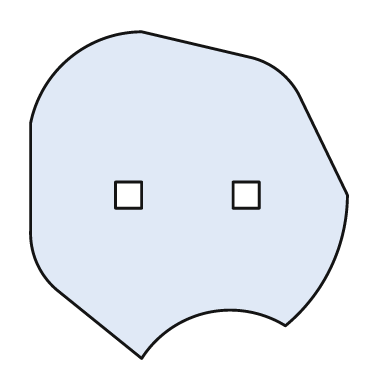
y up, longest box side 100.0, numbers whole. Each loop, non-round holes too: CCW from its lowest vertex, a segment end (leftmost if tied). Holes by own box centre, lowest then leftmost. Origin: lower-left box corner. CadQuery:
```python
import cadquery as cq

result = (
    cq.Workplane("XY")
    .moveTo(34.0, 0.0)
    .threePointArc((54.0, 14.0), (78.0, 10.0))
    .threePointArc((92.0, 28.0), (97.0, 50.0))
    .lineTo(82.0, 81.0)
    .threePointArc((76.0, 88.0), (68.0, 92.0))
    .lineTo(34.0, 100.0)
    .threePointArc((12.0, 92.0), (0.0, 72.0))
    .lineTo(0.0, 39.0)
    .threePointArc((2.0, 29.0), (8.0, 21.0))
    .close()
    .moveTo(26.0, 46.0)
    .lineTo(34.0, 46.0)
    .lineTo(34.0, 54.0)
    .lineTo(26.0, 54.0)
    .close()
    .moveTo(62.0, 46.0)
    .lineTo(70.0, 46.0)
    .lineTo(70.0, 54.0)
    .lineTo(62.0, 54.0)
    .close()
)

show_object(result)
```